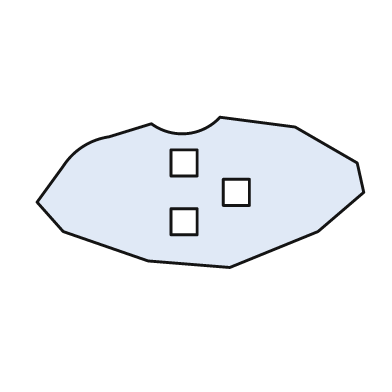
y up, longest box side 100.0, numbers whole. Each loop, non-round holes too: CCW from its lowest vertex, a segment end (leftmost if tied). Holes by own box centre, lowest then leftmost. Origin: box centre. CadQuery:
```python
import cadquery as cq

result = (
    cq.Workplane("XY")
    .moveTo(9.0, -23.0)
    .lineTo(36.0, -12.0)
    .lineTo(50.0, 0.0)
    .lineTo(48.0, 9.0)
    .lineTo(29.0, 20.0)
    .lineTo(6.0, 23.0)
    .threePointArc((-4.0, 18.0), (-15.0, 21.0))
    .lineTo(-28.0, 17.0)
    .threePointArc((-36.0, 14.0), (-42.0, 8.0))
    .lineTo(-50.0, -3.0)
    .lineTo(-42.0, -12.0)
    .lineTo(-16.0, -21.0)
    .close()
    .moveTo(-9.0, -13.0)
    .lineTo(-1.0, -13.0)
    .lineTo(-1.0, -5.0)
    .lineTo(-9.0, -5.0)
    .close()
    .moveTo(7.0, -4.0)
    .lineTo(15.0, -4.0)
    .lineTo(15.0, 4.0)
    .lineTo(7.0, 4.0)
    .close()
    .moveTo(-9.0, 5.0)
    .lineTo(-1.0, 5.0)
    .lineTo(-1.0, 13.0)
    .lineTo(-9.0, 13.0)
    .close()
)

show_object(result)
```